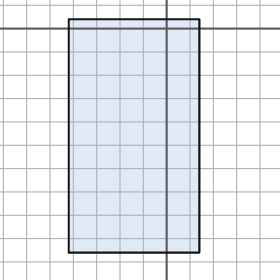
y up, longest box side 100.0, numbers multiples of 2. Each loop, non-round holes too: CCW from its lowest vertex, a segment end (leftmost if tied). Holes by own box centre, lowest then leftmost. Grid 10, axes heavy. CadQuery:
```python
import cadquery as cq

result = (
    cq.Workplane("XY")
    .moveTo(-42.0, -96.0)
    .lineTo(14.0, -96.0)
    .lineTo(14.0, 4.0)
    .lineTo(-42.0, 4.0)
    .close()
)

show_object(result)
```